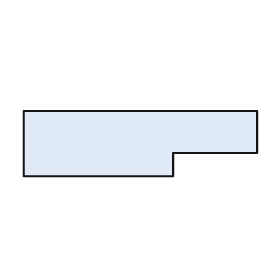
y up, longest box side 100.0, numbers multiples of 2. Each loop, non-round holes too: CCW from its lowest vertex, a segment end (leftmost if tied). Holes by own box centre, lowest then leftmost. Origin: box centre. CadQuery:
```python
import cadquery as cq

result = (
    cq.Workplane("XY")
    .moveTo(-50.0, -14.0)
    .lineTo(14.0, -14.0)
    .lineTo(14.0, -4.0)
    .lineTo(50.0, -4.0)
    .lineTo(50.0, 14.0)
    .lineTo(-50.0, 14.0)
    .close()
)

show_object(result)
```